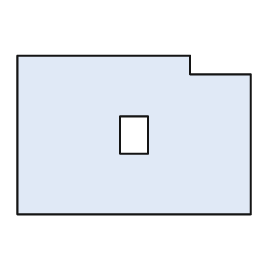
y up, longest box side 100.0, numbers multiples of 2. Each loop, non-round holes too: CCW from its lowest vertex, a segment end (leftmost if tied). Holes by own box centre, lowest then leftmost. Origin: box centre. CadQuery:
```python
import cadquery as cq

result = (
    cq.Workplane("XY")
    .moveTo(-50.0, -34.0)
    .lineTo(50.0, -34.0)
    .lineTo(50.0, 26.0)
    .lineTo(24.0, 26.0)
    .lineTo(24.0, 34.0)
    .lineTo(-50.0, 34.0)
    .close()
    .moveTo(-6.0, -8.0)
    .lineTo(6.0, -8.0)
    .lineTo(6.0, 8.0)
    .lineTo(-6.0, 8.0)
    .close()
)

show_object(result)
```